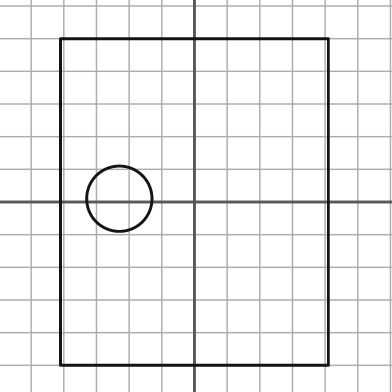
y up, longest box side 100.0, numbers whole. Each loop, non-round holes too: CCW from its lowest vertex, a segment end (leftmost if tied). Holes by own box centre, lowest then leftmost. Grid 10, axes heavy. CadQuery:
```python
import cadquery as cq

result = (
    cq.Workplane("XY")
    .moveTo(-41.0, -50.0)
    .lineTo(41.0, -50.0)
    .lineTo(41.0, 50.0)
    .lineTo(-41.0, 50.0)
    .close()
    .moveTo(-23.0, 1.0)
    .circle(10.0)
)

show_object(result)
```